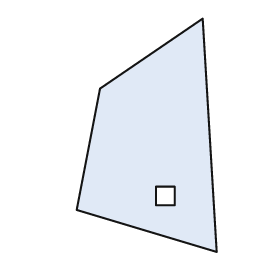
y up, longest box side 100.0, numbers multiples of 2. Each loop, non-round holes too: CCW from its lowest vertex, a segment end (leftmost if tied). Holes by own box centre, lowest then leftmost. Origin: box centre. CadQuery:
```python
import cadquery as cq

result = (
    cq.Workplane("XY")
    .moveTo(30.0, -50.0)
    .lineTo(24.0, 50.0)
    .lineTo(-20.0, 20.0)
    .lineTo(-30.0, -32.0)
    .close()
    .moveTo(4.0, -30.0)
    .lineTo(12.0, -30.0)
    .lineTo(12.0, -22.0)
    .lineTo(4.0, -22.0)
    .close()
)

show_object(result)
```